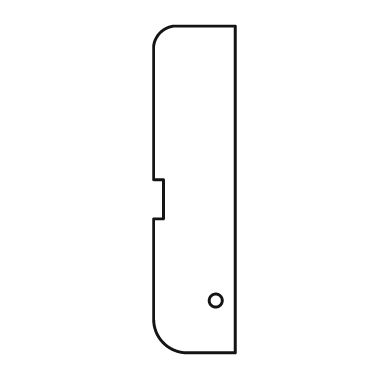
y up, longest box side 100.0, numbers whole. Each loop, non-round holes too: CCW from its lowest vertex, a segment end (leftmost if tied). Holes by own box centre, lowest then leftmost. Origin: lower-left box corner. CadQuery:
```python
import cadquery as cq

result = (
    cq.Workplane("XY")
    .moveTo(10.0, 0.0)
    .lineTo(25.0, 0.0)
    .lineTo(25.0, 100.0)
    .lineTo(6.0, 100.0)
    .threePointArc((2.0, 98.0), (0.0, 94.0))
    .lineTo(0.0, 53.0)
    .lineTo(3.0, 53.0)
    .lineTo(3.0, 41.0)
    .lineTo(0.0, 41.0)
    .lineTo(0.0, 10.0)
    .threePointArc((3.0, 3.0), (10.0, 0.0))
    .close()
    .moveTo(19.0, 16.0)
    .circle(2.0)
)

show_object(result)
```